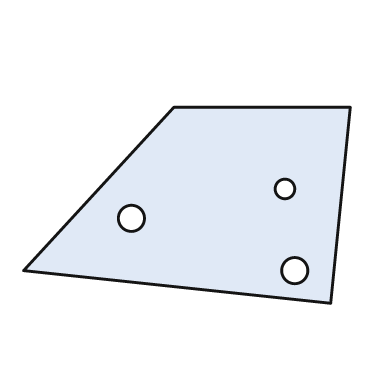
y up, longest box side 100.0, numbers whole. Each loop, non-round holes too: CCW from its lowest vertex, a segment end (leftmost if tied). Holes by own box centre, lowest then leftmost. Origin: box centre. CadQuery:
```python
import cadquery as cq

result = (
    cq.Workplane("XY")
    .moveTo(44.0, -30.0)
    .lineTo(50.0, 30.0)
    .lineTo(-4.0, 30.0)
    .lineTo(-50.0, -20.0)
    .close()
    .moveTo(33.0, -20.0)
    .circle(4.0)
    .moveTo(-17.0, -4.0)
    .circle(4.0)
    .moveTo(30.0, 5.0)
    .circle(3.0)
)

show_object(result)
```